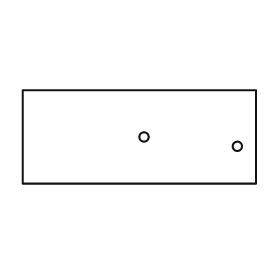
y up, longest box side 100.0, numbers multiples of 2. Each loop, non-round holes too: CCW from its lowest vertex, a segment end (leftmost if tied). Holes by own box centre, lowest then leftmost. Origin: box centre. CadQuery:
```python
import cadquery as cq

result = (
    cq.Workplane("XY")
    .moveTo(-50.0, -20.0)
    .lineTo(50.0, -20.0)
    .lineTo(50.0, 20.0)
    .lineTo(-50.0, 20.0)
    .close()
    .moveTo(42.0, -4.0)
    .circle(2.0)
    .moveTo(2.0, 0.0)
    .circle(2.0)
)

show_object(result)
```